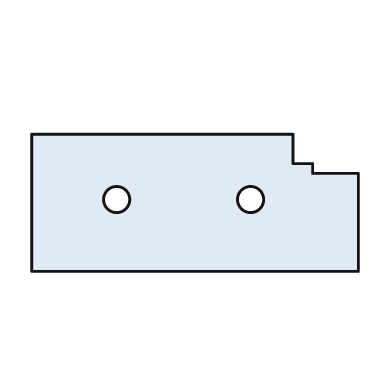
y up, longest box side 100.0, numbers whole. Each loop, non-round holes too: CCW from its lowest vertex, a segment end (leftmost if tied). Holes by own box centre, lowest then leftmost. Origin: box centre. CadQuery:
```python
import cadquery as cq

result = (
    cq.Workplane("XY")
    .moveTo(-50.0, -21.0)
    .lineTo(50.0, -21.0)
    .lineTo(50.0, 9.0)
    .lineTo(36.0, 9.0)
    .lineTo(36.0, 12.0)
    .lineTo(30.0, 12.0)
    .lineTo(30.0, 21.0)
    .lineTo(-50.0, 21.0)
    .close()
    .moveTo(-24.0, 1.0)
    .circle(4.0)
    .moveTo(17.0, 1.0)
    .circle(4.0)
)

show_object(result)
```